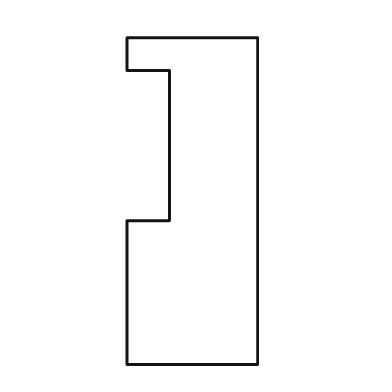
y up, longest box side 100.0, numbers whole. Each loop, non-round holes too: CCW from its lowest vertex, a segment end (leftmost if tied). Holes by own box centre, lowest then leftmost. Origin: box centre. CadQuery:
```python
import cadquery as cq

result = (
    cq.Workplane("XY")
    .moveTo(-20.0, -50.0)
    .lineTo(20.0, -50.0)
    .lineTo(20.0, 50.0)
    .lineTo(-20.0, 50.0)
    .lineTo(-20.0, 40.0)
    .lineTo(-7.0, 40.0)
    .lineTo(-7.0, -6.0)
    .lineTo(-20.0, -6.0)
    .close()
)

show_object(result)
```